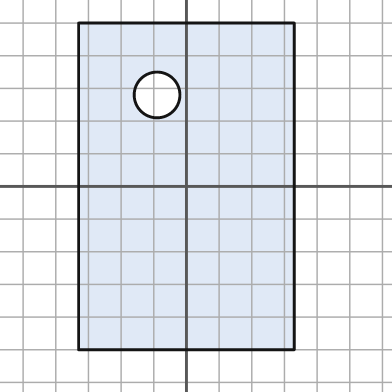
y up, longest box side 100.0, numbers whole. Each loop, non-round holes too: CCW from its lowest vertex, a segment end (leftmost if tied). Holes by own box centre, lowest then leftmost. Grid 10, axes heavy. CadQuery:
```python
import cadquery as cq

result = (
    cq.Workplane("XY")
    .moveTo(-33.0, -50.0)
    .lineTo(33.0, -50.0)
    .lineTo(33.0, 50.0)
    .lineTo(-33.0, 50.0)
    .close()
    .moveTo(-9.0, 28.0)
    .circle(7.0)
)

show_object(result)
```